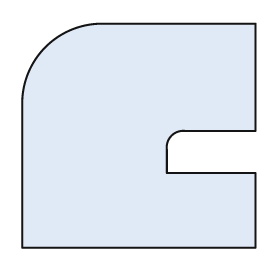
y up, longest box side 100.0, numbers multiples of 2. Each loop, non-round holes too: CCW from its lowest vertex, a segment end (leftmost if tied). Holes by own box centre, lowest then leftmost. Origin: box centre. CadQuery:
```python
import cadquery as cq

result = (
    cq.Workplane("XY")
    .moveTo(-50.0, -48.0)
    .lineTo(50.0, -48.0)
    .lineTo(50.0, -16.0)
    .lineTo(12.0, -16.0)
    .lineTo(12.0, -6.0)
    .threePointArc((14.0, 0.0), (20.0, 2.0))
    .lineTo(50.0, 2.0)
    .lineTo(50.0, 48.0)
    .lineTo(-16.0, 48.0)
    .threePointArc((-40.0, 38.0), (-50.0, 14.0))
    .close()
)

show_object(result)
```